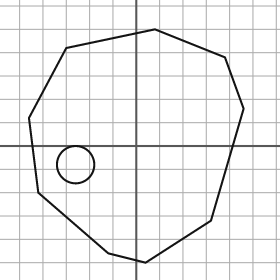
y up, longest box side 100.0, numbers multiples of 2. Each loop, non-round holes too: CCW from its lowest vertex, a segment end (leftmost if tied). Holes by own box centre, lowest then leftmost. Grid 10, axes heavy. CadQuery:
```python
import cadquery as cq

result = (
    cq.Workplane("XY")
    .moveTo(4.0, -50.0)
    .lineTo(32.0, -32.0)
    .lineTo(46.0, 16.0)
    .lineTo(38.0, 38.0)
    .lineTo(8.0, 50.0)
    .lineTo(-30.0, 42.0)
    .lineTo(-46.0, 12.0)
    .lineTo(-42.0, -20.0)
    .lineTo(-12.0, -46.0)
    .close()
    .moveTo(-26.0, -8.0)
    .circle(8.0)
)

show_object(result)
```